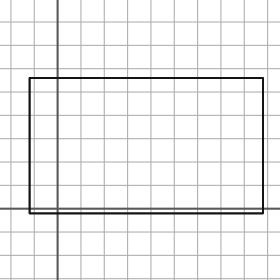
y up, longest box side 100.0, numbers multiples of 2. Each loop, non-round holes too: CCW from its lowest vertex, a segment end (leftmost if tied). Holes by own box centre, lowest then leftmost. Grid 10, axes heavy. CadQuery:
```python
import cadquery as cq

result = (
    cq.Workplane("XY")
    .moveTo(-12.0, -2.0)
    .lineTo(88.0, -2.0)
    .lineTo(88.0, 56.0)
    .lineTo(-12.0, 56.0)
    .close()
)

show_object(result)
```